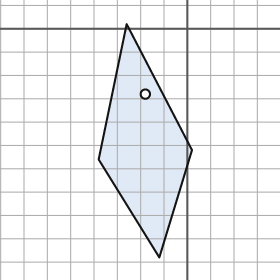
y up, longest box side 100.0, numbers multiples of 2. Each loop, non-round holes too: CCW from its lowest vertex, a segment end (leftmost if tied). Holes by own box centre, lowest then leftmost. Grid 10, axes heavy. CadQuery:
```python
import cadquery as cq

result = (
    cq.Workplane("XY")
    .moveTo(-12.0, -98.0)
    .lineTo(2.0, -52.0)
    .lineTo(-26.0, 2.0)
    .lineTo(-38.0, -56.0)
    .close()
    .moveTo(-18.0, -28.0)
    .circle(2.0)
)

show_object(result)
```